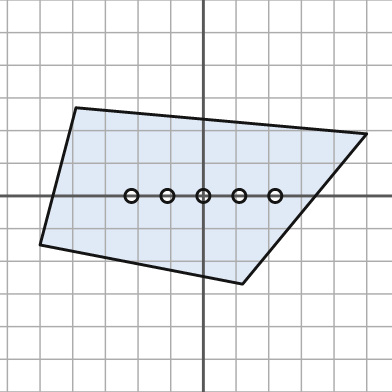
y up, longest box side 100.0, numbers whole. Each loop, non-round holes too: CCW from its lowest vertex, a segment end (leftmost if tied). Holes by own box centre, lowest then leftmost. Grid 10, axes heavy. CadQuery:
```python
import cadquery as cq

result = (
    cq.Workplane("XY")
    .moveTo(12.0, -27.0)
    .lineTo(50.0, 19.0)
    .lineTo(-39.0, 27.0)
    .lineTo(-50.0, -15.0)
    .close()
    .moveTo(-22.0, 0.0)
    .circle(2.0)
    .moveTo(-11.0, 0.0)
    .circle(2.0)
    .moveTo(0.0, 0.0)
    .circle(2.0)
    .moveTo(11.0, 0.0)
    .circle(2.0)
    .moveTo(22.0, 0.0)
    .circle(2.0)
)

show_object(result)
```